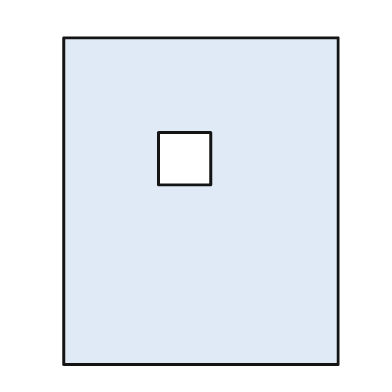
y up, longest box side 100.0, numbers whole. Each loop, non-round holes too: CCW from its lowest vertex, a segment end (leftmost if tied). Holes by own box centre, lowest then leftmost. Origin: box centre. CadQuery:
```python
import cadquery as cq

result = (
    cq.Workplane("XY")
    .moveTo(-42.0, -50.0)
    .lineTo(42.0, -50.0)
    .lineTo(42.0, 50.0)
    .lineTo(-42.0, 50.0)
    .close()
    .moveTo(-13.0, 5.0)
    .lineTo(3.0, 5.0)
    .lineTo(3.0, 21.0)
    .lineTo(-13.0, 21.0)
    .close()
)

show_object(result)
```